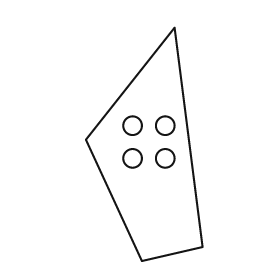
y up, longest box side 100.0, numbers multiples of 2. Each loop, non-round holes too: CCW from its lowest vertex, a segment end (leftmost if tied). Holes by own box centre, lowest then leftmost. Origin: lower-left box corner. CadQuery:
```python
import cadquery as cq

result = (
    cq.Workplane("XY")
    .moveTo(24.0, 0.0)
    .lineTo(50.0, 6.0)
    .lineTo(38.0, 100.0)
    .lineTo(0.0, 52.0)
    .close()
    .moveTo(20.0, 44.0)
    .circle(4.0)
    .moveTo(34.0, 44.0)
    .circle(4.0)
    .moveTo(20.0, 58.0)
    .circle(4.0)
    .moveTo(34.0, 58.0)
    .circle(4.0)
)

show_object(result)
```